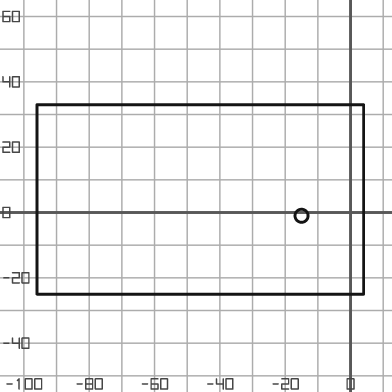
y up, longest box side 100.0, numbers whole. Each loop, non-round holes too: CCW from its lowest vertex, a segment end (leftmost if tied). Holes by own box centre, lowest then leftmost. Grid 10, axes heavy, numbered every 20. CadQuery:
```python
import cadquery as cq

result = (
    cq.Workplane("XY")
    .moveTo(-96.0, -25.0)
    .lineTo(4.0, -25.0)
    .lineTo(4.0, 33.0)
    .lineTo(-96.0, 33.0)
    .close()
    .moveTo(-15.0, -1.0)
    .circle(2.0)
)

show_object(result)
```